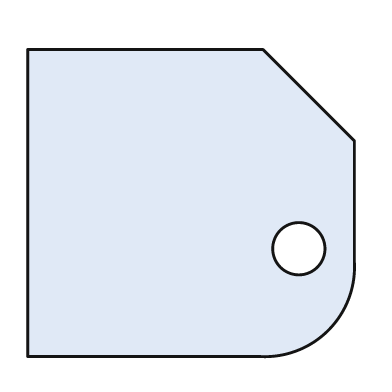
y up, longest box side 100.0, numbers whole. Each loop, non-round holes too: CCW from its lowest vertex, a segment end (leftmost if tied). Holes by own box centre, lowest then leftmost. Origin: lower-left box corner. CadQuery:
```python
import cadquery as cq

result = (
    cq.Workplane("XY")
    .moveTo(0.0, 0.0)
    .lineTo(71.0, 0.0)
    .threePointArc((92.0, 8.0), (100.0, 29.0))
    .lineTo(100.0, 66.0)
    .lineTo(72.0, 94.0)
    .lineTo(0.0, 94.0)
    .close()
    .moveTo(83.0, 33.0)
    .circle(8.0)
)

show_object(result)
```